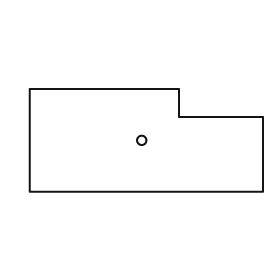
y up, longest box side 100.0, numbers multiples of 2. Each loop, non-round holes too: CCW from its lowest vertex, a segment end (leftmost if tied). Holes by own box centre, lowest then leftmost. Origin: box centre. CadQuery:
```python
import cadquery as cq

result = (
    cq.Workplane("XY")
    .moveTo(-50.0, -22.0)
    .lineTo(50.0, -22.0)
    .lineTo(50.0, 10.0)
    .lineTo(14.0, 10.0)
    .lineTo(14.0, 22.0)
    .lineTo(-50.0, 22.0)
    .close()
    .moveTo(-2.0, 0.0)
    .circle(2.0)
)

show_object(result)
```